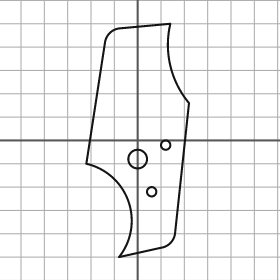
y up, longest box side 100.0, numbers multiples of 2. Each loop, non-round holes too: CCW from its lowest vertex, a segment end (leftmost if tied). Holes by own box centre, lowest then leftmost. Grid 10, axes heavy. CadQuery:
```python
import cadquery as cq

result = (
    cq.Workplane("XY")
    .moveTo(-8.0, -50.0)
    .lineTo(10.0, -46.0)
    .threePointArc((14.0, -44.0), (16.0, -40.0))
    .lineTo(22.0, 16.0)
    .threePointArc((14.0, 32.0), (14.0, 50.0))
    .lineTo(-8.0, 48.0)
    .threePointArc((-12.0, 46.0), (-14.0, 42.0))
    .lineTo(-22.0, -10.0)
    .threePointArc((-4.0, -26.0), (-8.0, -50.0))
    .close()
    .moveTo(6.0, -22.0)
    .circle(2.0)
    .moveTo(0.0, -8.0)
    .circle(4.0)
    .moveTo(12.0, -2.0)
    .circle(2.0)
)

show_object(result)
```